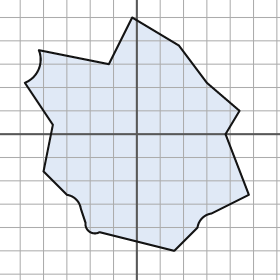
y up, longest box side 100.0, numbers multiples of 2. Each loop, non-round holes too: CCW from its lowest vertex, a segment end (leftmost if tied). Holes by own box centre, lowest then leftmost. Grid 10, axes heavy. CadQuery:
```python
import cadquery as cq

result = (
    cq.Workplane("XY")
    .moveTo(16.0, -50.0)
    .lineTo(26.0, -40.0)
    .threePointArc((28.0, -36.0), (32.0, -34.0))
    .lineTo(48.0, -26.0)
    .lineTo(38.0, 0.0)
    .lineTo(44.0, 10.0)
    .lineTo(30.0, 22.0)
    .lineTo(18.0, 38.0)
    .lineTo(-2.0, 50.0)
    .lineTo(-12.0, 30.0)
    .lineTo(-42.0, 36.0)
    .threePointArc((-42.0, 28.0), (-48.0, 22.0))
    .lineTo(-36.0, 4.0)
    .lineTo(-40.0, -16.0)
    .lineTo(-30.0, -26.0)
    .threePointArc((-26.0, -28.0), (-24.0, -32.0))
    .lineTo(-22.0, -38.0)
    .threePointArc((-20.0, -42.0), (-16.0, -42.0))
    .close()
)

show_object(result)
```